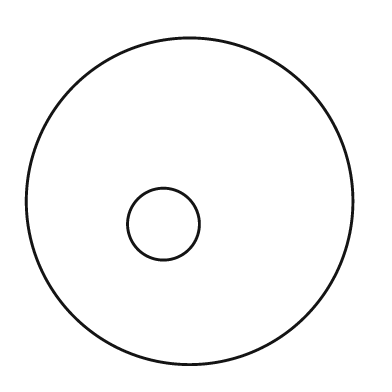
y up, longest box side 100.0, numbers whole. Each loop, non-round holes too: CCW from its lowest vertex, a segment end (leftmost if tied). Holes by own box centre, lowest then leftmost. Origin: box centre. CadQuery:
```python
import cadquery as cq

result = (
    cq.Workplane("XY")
    .moveTo(0.0, 0.0)
    .circle(50.0)
    .moveTo(-8.0, -7.0)
    .circle(11.0)
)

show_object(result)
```